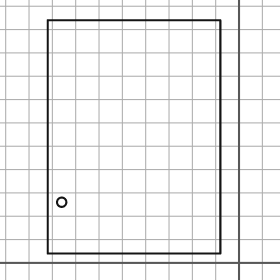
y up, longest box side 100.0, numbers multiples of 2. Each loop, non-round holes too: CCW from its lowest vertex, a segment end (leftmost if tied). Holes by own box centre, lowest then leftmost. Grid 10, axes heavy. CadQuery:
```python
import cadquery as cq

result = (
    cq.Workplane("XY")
    .moveTo(-82.0, 4.0)
    .lineTo(-8.0, 4.0)
    .lineTo(-8.0, 104.0)
    .lineTo(-82.0, 104.0)
    .close()
    .moveTo(-76.0, 26.0)
    .circle(2.0)
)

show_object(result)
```